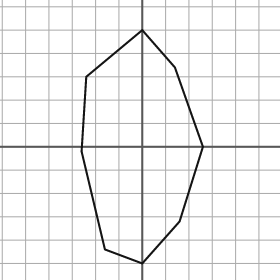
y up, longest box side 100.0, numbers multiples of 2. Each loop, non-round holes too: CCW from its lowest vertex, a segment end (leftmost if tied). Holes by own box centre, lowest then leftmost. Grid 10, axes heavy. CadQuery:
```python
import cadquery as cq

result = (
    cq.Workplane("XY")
    .moveTo(0.0, -50.0)
    .lineTo(16.0, -32.0)
    .lineTo(26.0, 0.0)
    .lineTo(14.0, 34.0)
    .lineTo(0.0, 50.0)
    .lineTo(-24.0, 30.0)
    .lineTo(-26.0, -2.0)
    .lineTo(-16.0, -44.0)
    .close()
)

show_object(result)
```